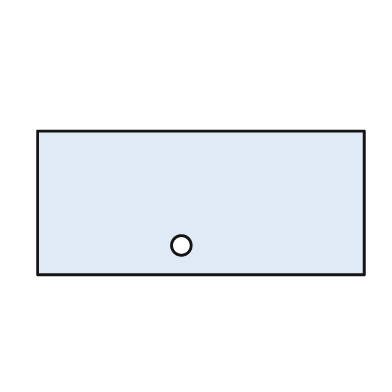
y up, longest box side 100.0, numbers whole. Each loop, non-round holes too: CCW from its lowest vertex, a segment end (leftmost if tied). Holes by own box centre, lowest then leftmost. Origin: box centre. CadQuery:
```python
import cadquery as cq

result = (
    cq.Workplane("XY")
    .moveTo(-50.0, -22.0)
    .lineTo(50.0, -22.0)
    .lineTo(50.0, 22.0)
    .lineTo(-50.0, 22.0)
    .close()
    .moveTo(-6.0, -13.0)
    .circle(3.0)
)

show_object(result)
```